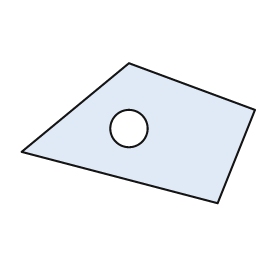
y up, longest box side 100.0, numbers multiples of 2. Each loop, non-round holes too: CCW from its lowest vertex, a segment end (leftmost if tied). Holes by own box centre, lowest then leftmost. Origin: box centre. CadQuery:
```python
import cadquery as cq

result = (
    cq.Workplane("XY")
    .moveTo(34.0, -30.0)
    .lineTo(50.0, 10.0)
    .lineTo(-4.0, 30.0)
    .lineTo(-50.0, -8.0)
    .close()
    .moveTo(-4.0, 2.0)
    .circle(8.0)
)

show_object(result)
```